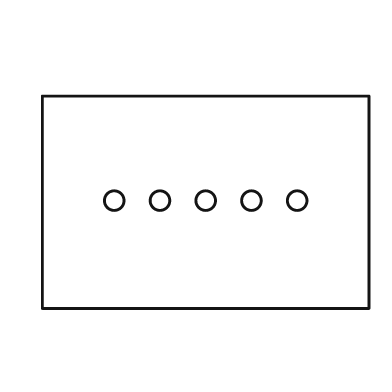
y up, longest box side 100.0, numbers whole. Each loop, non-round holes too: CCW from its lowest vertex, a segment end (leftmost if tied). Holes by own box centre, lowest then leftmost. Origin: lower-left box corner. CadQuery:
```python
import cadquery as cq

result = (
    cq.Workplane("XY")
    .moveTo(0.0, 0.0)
    .lineTo(100.0, 0.0)
    .lineTo(100.0, 65.0)
    .lineTo(0.0, 65.0)
    .close()
    .moveTo(22.0, 33.0)
    .circle(3.0)
    .moveTo(36.0, 33.0)
    .circle(3.0)
    .moveTo(50.0, 33.0)
    .circle(3.0)
    .moveTo(64.0, 33.0)
    .circle(3.0)
    .moveTo(78.0, 33.0)
    .circle(3.0)
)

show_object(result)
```